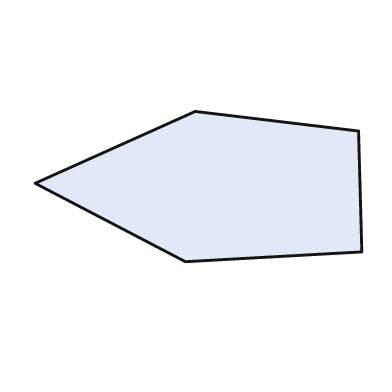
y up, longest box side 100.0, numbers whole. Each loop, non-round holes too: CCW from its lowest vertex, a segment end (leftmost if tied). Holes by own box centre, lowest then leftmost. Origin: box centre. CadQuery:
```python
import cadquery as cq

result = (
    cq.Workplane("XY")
    .moveTo(-4.0, -23.0)
    .lineTo(50.0, -20.0)
    .lineTo(49.0, 17.0)
    .lineTo(-1.0, 23.0)
    .lineTo(-50.0, 1.0)
    .close()
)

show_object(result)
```